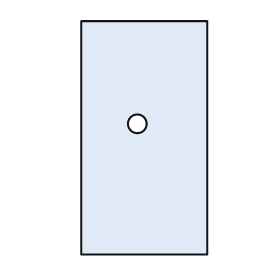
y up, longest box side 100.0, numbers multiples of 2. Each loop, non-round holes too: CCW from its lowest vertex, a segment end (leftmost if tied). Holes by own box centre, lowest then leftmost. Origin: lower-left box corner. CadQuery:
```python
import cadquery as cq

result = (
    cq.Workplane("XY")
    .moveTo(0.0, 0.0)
    .lineTo(54.0, 0.0)
    .lineTo(54.0, 100.0)
    .lineTo(0.0, 100.0)
    .close()
    .moveTo(24.0, 56.0)
    .circle(4.0)
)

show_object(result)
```